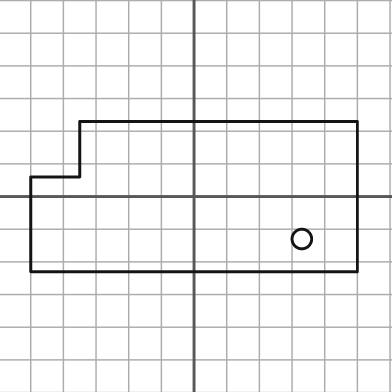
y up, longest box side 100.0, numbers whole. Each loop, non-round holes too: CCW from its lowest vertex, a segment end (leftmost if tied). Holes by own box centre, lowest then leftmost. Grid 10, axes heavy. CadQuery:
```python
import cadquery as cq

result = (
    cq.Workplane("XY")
    .moveTo(-50.0, -23.0)
    .lineTo(50.0, -23.0)
    .lineTo(50.0, 23.0)
    .lineTo(-35.0, 23.0)
    .lineTo(-35.0, 6.0)
    .lineTo(-50.0, 6.0)
    .close()
    .moveTo(33.0, -13.0)
    .circle(3.0)
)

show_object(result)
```